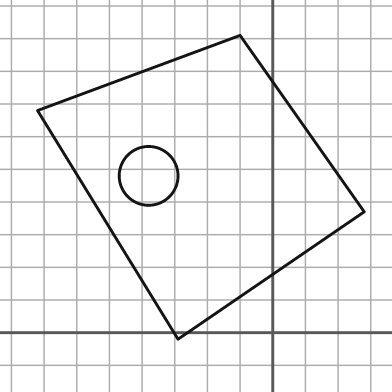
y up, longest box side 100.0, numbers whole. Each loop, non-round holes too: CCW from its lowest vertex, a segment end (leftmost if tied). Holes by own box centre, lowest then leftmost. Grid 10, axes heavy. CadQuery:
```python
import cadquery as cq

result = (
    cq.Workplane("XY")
    .moveTo(-29.0, -2.0)
    .lineTo(28.0, 37.0)
    .lineTo(-10.0, 91.0)
    .lineTo(-72.0, 68.0)
    .close()
    .moveTo(-38.0, 48.0)
    .circle(9.0)
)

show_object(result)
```